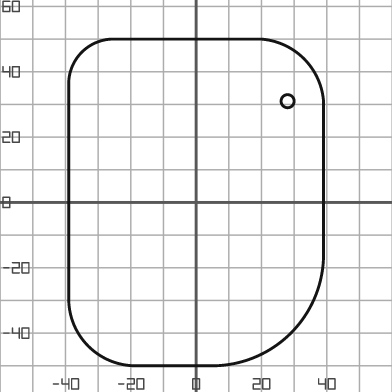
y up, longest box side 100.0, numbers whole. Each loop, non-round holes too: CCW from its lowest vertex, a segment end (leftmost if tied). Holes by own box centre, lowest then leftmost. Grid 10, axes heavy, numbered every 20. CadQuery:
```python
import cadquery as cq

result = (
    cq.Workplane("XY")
    .moveTo(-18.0, -50.0)
    .lineTo(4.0, -50.0)
    .threePointArc((29.0, -40.0), (39.0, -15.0))
    .lineTo(39.0, 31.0)
    .threePointArc((33.0, 44.0), (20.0, 50.0))
    .lineTo(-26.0, 50.0)
    .threePointArc((-35.0, 46.0), (-39.0, 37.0))
    .lineTo(-39.0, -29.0)
    .threePointArc((-33.0, -44.0), (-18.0, -50.0))
    .close()
    .moveTo(28.0, 31.0)
    .circle(2.0)
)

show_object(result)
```